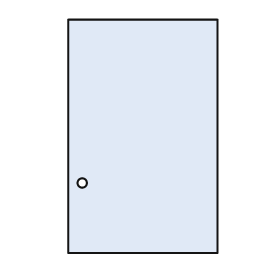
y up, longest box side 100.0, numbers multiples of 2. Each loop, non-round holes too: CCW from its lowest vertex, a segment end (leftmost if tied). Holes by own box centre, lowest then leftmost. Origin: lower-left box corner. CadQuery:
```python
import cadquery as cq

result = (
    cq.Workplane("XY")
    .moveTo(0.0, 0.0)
    .lineTo(64.0, 0.0)
    .lineTo(64.0, 100.0)
    .lineTo(0.0, 100.0)
    .close()
    .moveTo(6.0, 30.0)
    .circle(2.0)
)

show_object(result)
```